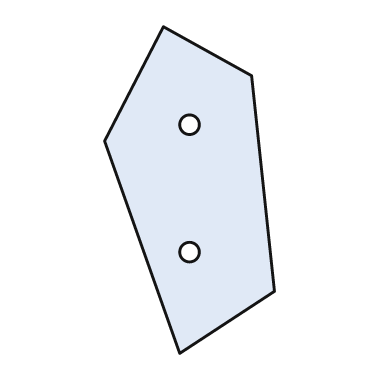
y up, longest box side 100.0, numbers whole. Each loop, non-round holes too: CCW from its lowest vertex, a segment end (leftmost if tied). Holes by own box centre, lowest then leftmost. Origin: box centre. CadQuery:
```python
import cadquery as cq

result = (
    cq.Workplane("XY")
    .moveTo(-3.0, -50.0)
    .lineTo(26.0, -31.0)
    .lineTo(19.0, 35.0)
    .lineTo(-8.0, 50.0)
    .lineTo(-26.0, 15.0)
    .close()
    .moveTo(0.0, -19.0)
    .circle(3.0)
    .moveTo(0.0, 20.0)
    .circle(3.0)
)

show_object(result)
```